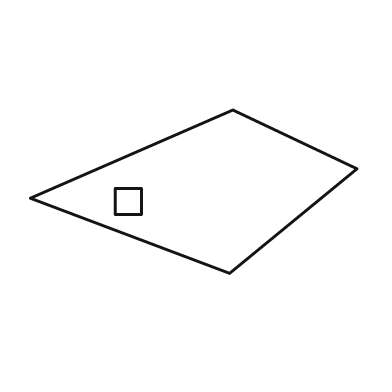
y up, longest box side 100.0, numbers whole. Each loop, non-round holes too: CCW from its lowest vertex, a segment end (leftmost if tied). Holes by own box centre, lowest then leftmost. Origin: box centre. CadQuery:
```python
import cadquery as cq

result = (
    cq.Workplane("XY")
    .moveTo(11.0, -25.0)
    .lineTo(50.0, 7.0)
    .lineTo(12.0, 25.0)
    .lineTo(-50.0, -2.0)
    .close()
    .moveTo(-24.0, -7.0)
    .lineTo(-16.0, -7.0)
    .lineTo(-16.0, 1.0)
    .lineTo(-24.0, 1.0)
    .close()
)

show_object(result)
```